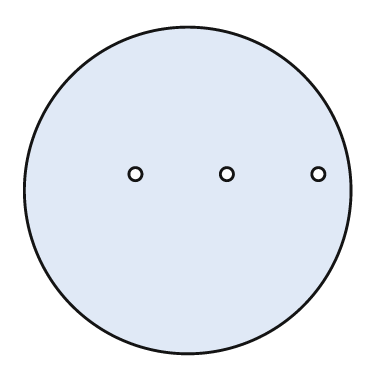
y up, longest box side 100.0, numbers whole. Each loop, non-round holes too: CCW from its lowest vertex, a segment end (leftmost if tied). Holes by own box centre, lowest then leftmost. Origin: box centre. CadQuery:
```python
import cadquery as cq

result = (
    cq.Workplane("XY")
    .moveTo(0.0, 0.0)
    .circle(50.0)
    .moveTo(-16.0, 5.0)
    .circle(2.0)
    .moveTo(12.0, 5.0)
    .circle(2.0)
    .moveTo(40.0, 5.0)
    .circle(2.0)
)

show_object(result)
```